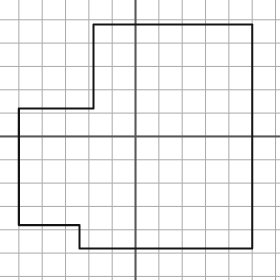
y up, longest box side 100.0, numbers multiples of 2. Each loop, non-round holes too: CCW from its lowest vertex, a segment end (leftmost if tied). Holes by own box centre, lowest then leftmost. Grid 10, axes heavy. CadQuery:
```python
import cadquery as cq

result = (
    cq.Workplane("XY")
    .moveTo(-24.0, -48.0)
    .lineTo(50.0, -48.0)
    .lineTo(50.0, 48.0)
    .lineTo(-18.0, 48.0)
    .lineTo(-18.0, 12.0)
    .lineTo(-50.0, 12.0)
    .lineTo(-50.0, -38.0)
    .lineTo(-24.0, -38.0)
    .close()
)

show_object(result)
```